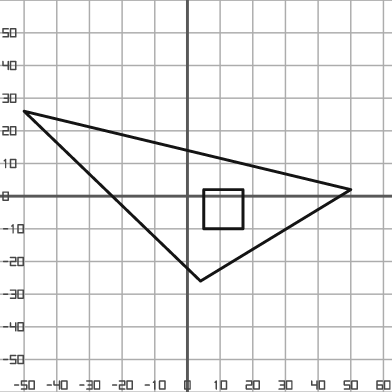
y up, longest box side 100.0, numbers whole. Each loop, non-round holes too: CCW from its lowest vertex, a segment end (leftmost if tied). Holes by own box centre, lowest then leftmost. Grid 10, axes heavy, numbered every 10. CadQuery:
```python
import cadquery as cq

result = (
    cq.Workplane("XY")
    .moveTo(4.0, -26.0)
    .lineTo(50.0, 2.0)
    .lineTo(-50.0, 26.0)
    .close()
    .moveTo(5.0, -10.0)
    .lineTo(17.0, -10.0)
    .lineTo(17.0, 2.0)
    .lineTo(5.0, 2.0)
    .close()
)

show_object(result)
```